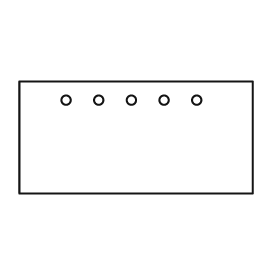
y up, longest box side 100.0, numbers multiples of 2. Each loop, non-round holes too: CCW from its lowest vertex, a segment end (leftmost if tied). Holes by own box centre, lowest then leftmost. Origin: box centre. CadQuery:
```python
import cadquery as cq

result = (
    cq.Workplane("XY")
    .moveTo(-50.0, -24.0)
    .lineTo(50.0, -24.0)
    .lineTo(50.0, 24.0)
    .lineTo(-50.0, 24.0)
    .close()
    .moveTo(-30.0, 16.0)
    .circle(2.0)
    .moveTo(-16.0, 16.0)
    .circle(2.0)
    .moveTo(-2.0, 16.0)
    .circle(2.0)
    .moveTo(12.0, 16.0)
    .circle(2.0)
    .moveTo(26.0, 16.0)
    .circle(2.0)
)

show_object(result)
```